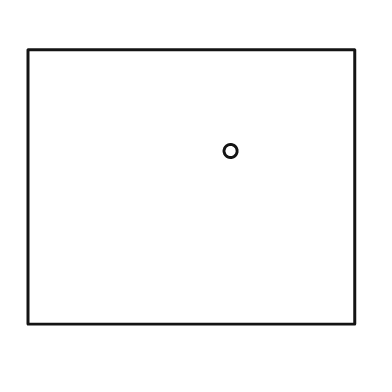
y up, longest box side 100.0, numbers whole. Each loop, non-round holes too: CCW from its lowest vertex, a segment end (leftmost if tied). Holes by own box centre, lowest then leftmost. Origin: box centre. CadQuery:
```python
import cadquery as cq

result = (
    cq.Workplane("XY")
    .moveTo(-50.0, -42.0)
    .lineTo(50.0, -42.0)
    .lineTo(50.0, 42.0)
    .lineTo(-50.0, 42.0)
    .close()
    .moveTo(12.0, 11.0)
    .circle(2.0)
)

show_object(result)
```